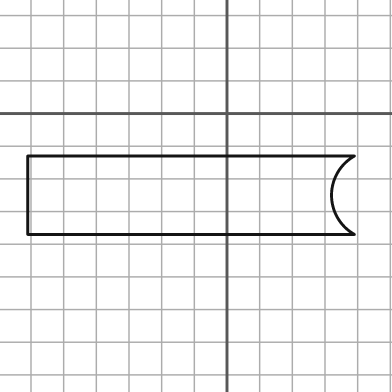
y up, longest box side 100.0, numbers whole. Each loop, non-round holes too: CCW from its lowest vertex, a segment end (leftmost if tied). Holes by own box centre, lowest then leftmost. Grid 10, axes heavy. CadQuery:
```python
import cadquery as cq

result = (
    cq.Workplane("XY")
    .moveTo(-61.0, -37.0)
    .lineTo(39.0, -37.0)
    .threePointArc((32.0, -25.0), (39.0, -13.0))
    .lineTo(-61.0, -13.0)
    .close()
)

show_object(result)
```